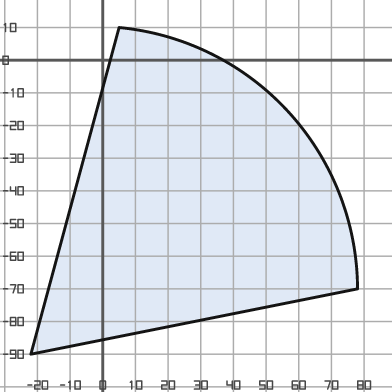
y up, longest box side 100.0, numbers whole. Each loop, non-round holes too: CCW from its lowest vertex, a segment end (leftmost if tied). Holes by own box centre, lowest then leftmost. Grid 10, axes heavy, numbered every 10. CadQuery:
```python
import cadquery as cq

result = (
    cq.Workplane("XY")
    .moveTo(-22.0, -90.0)
    .lineTo(78.0, -70.0)
    .threePointArc((57.0, -16.0), (5.0, 10.0))
    .close()
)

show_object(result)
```